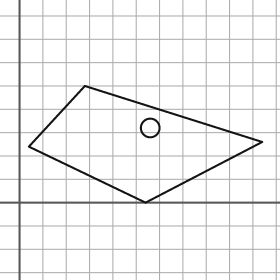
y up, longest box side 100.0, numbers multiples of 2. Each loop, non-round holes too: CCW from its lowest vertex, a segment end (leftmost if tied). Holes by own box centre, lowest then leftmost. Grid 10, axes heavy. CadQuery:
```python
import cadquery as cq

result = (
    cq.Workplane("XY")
    .moveTo(54.0, 0.0)
    .lineTo(104.0, 26.0)
    .lineTo(28.0, 50.0)
    .lineTo(4.0, 24.0)
    .close()
    .moveTo(56.0, 32.0)
    .circle(4.0)
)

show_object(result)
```